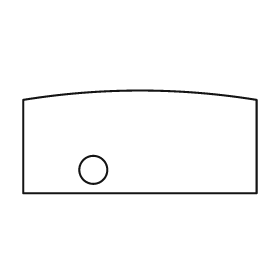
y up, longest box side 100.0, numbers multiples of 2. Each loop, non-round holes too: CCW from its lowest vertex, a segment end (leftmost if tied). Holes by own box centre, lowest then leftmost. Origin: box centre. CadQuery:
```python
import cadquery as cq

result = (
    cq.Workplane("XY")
    .moveTo(-50.0, -22.0)
    .lineTo(50.0, -22.0)
    .lineTo(50.0, 18.0)
    .threePointArc((0.0, 22.0), (-50.0, 18.0))
    .close()
    .moveTo(-20.0, -12.0)
    .circle(6.0)
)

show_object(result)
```